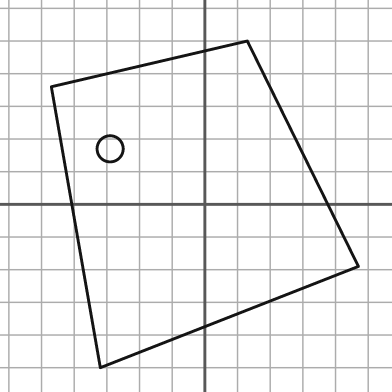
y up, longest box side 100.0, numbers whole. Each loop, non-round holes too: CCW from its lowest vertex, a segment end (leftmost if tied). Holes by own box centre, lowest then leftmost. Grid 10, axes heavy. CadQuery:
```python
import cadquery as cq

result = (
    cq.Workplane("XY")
    .moveTo(-32.0, -50.0)
    .lineTo(47.0, -19.0)
    .lineTo(13.0, 50.0)
    .lineTo(-47.0, 36.0)
    .close()
    .moveTo(-29.0, 17.0)
    .circle(4.0)
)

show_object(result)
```